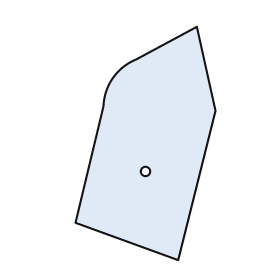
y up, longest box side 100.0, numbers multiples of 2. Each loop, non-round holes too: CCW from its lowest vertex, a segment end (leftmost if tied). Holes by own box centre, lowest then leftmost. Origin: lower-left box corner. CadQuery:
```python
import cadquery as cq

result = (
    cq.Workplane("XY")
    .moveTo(44.0, 0.0)
    .lineTo(60.0, 64.0)
    .lineTo(52.0, 100.0)
    .lineTo(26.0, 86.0)
    .threePointArc((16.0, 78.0), (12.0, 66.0))
    .lineTo(0.0, 16.0)
    .close()
    .moveTo(30.0, 38.0)
    .circle(2.0)
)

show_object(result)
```